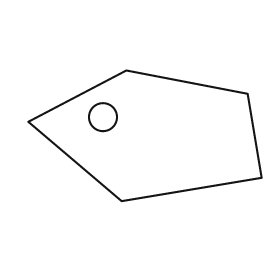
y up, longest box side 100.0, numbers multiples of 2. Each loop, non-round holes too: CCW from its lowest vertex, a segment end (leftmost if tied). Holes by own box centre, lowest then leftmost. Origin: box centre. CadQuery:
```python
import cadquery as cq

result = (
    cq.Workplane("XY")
    .moveTo(-10.0, -28.0)
    .lineTo(50.0, -18.0)
    .lineTo(44.0, 18.0)
    .lineTo(-8.0, 28.0)
    .lineTo(-50.0, 6.0)
    .close()
    .moveTo(-18.0, 8.0)
    .circle(6.0)
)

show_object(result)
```